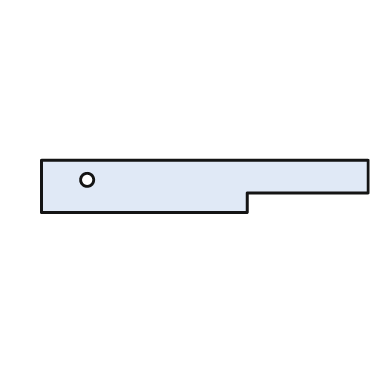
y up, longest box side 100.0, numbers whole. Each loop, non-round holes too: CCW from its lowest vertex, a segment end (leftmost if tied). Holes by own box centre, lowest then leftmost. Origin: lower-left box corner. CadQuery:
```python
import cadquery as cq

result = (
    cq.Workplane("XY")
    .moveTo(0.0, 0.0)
    .lineTo(63.0, 0.0)
    .lineTo(63.0, 6.0)
    .lineTo(100.0, 6.0)
    .lineTo(100.0, 16.0)
    .lineTo(0.0, 16.0)
    .close()
    .moveTo(14.0, 10.0)
    .circle(2.0)
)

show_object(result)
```